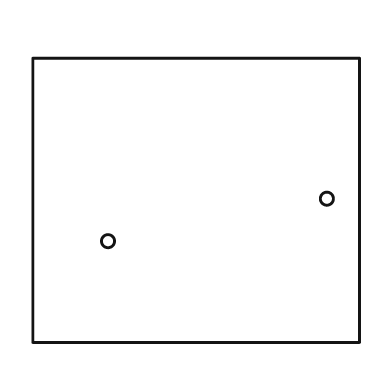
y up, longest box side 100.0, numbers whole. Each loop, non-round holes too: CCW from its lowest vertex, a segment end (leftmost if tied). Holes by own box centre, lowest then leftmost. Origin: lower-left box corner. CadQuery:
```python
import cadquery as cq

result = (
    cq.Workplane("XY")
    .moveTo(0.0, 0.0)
    .lineTo(100.0, 0.0)
    .lineTo(100.0, 87.0)
    .lineTo(0.0, 87.0)
    .close()
    .moveTo(23.0, 31.0)
    .circle(2.0)
    .moveTo(90.0, 44.0)
    .circle(2.0)
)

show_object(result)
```